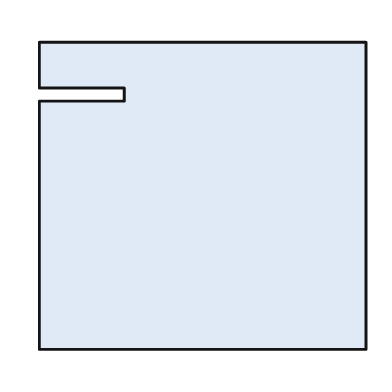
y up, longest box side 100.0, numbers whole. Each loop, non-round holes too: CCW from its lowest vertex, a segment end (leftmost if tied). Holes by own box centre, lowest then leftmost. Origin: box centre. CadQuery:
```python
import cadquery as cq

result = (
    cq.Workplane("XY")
    .moveTo(-50.0, -47.0)
    .lineTo(50.0, -47.0)
    .lineTo(50.0, 47.0)
    .lineTo(-50.0, 47.0)
    .lineTo(-50.0, 33.0)
    .lineTo(-24.0, 33.0)
    .lineTo(-24.0, 29.0)
    .lineTo(-50.0, 29.0)
    .close()
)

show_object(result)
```